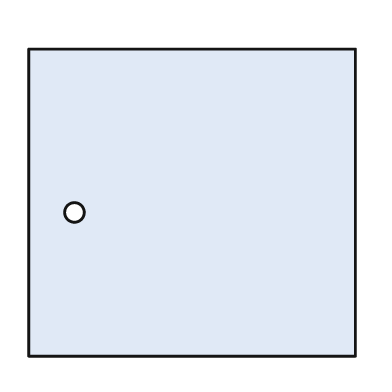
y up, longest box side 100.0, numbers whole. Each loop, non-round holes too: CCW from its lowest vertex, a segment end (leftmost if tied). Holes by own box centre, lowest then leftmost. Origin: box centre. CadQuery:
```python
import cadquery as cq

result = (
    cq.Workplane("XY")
    .moveTo(-50.0, -47.0)
    .lineTo(50.0, -47.0)
    .lineTo(50.0, 47.0)
    .lineTo(-50.0, 47.0)
    .close()
    .moveTo(-36.0, -3.0)
    .circle(3.0)
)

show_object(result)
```